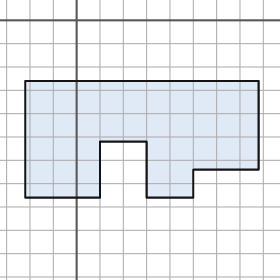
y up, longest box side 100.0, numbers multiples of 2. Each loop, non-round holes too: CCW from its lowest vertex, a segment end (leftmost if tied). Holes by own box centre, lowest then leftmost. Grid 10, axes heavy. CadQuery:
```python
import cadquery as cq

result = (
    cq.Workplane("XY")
    .moveTo(-22.0, -76.0)
    .lineTo(10.0, -76.0)
    .lineTo(10.0, -52.0)
    .lineTo(30.0, -52.0)
    .lineTo(30.0, -76.0)
    .lineTo(50.0, -76.0)
    .lineTo(50.0, -64.0)
    .lineTo(78.0, -64.0)
    .lineTo(78.0, -26.0)
    .lineTo(-22.0, -26.0)
    .close()
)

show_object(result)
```